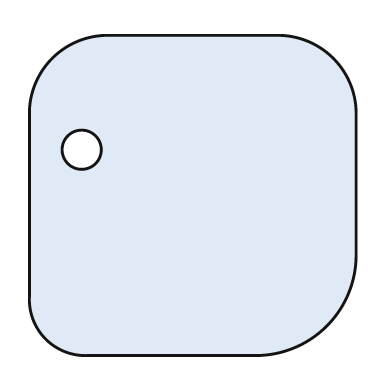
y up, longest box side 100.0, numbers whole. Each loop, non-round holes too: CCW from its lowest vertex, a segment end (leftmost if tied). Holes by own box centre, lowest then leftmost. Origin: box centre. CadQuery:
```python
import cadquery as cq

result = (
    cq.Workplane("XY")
    .moveTo(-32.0, -49.0)
    .lineTo(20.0, -49.0)
    .threePointArc((41.0, -40.0), (50.0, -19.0))
    .lineTo(50.0, 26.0)
    .threePointArc((43.0, 42.0), (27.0, 49.0))
    .lineTo(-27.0, 49.0)
    .threePointArc((-43.0, 42.0), (-50.0, 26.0))
    .lineTo(-50.0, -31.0)
    .threePointArc((-45.0, -44.0), (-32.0, -49.0))
    .close()
    .moveTo(-34.0, 14.0)
    .circle(6.0)
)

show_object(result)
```